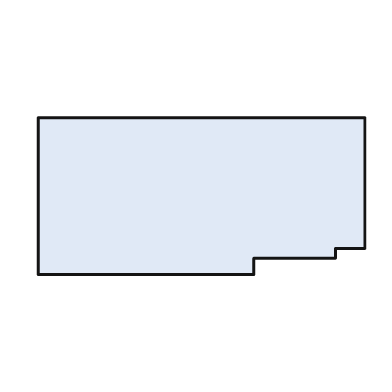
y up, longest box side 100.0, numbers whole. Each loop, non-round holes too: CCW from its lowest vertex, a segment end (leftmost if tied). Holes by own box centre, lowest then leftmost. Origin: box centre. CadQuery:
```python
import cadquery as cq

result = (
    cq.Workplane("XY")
    .moveTo(-50.0, -24.0)
    .lineTo(16.0, -24.0)
    .lineTo(16.0, -19.0)
    .lineTo(41.0, -19.0)
    .lineTo(41.0, -16.0)
    .lineTo(50.0, -16.0)
    .lineTo(50.0, 24.0)
    .lineTo(-50.0, 24.0)
    .close()
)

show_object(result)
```